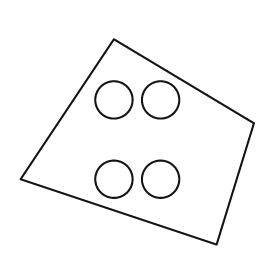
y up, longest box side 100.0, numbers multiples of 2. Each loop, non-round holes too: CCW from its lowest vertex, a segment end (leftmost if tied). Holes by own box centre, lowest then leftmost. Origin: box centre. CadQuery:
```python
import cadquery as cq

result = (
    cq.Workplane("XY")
    .moveTo(34.0, -44.0)
    .lineTo(50.0, 8.0)
    .lineTo(-10.0, 44.0)
    .lineTo(-50.0, -16.0)
    .close()
    .moveTo(-10.0, -16.0)
    .circle(8.0)
    .moveTo(10.0, -16.0)
    .circle(8.0)
    .moveTo(-10.0, 18.0)
    .circle(8.0)
    .moveTo(10.0, 18.0)
    .circle(8.0)
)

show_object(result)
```